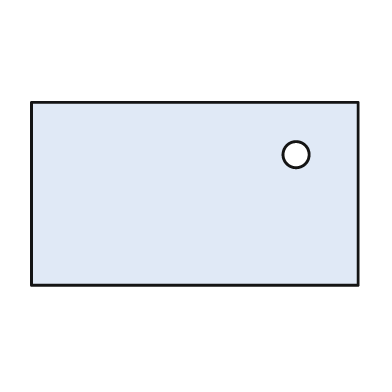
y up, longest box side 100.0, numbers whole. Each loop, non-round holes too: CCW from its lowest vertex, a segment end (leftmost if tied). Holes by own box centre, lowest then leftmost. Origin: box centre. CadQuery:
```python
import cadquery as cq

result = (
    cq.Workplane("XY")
    .moveTo(-50.0, -28.0)
    .lineTo(50.0, -28.0)
    .lineTo(50.0, 28.0)
    .lineTo(-50.0, 28.0)
    .close()
    .moveTo(31.0, 12.0)
    .circle(4.0)
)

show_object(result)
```